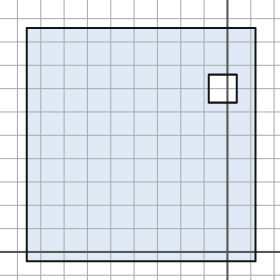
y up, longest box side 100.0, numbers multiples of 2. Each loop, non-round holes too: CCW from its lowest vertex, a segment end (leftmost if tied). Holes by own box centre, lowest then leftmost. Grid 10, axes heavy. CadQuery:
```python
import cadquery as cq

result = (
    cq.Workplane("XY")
    .moveTo(-86.0, -4.0)
    .lineTo(12.0, -4.0)
    .lineTo(12.0, 96.0)
    .lineTo(-86.0, 96.0)
    .close()
    .moveTo(-8.0, 64.0)
    .lineTo(4.0, 64.0)
    .lineTo(4.0, 76.0)
    .lineTo(-8.0, 76.0)
    .close()
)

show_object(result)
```